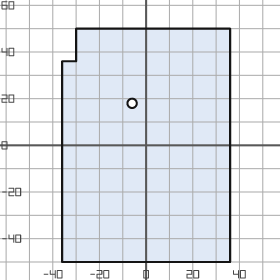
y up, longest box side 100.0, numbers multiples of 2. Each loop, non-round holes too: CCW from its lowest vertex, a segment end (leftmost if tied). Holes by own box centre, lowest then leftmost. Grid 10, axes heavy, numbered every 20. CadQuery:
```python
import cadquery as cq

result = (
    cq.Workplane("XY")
    .moveTo(-36.0, -50.0)
    .lineTo(36.0, -50.0)
    .lineTo(36.0, 50.0)
    .lineTo(-30.0, 50.0)
    .lineTo(-30.0, 36.0)
    .lineTo(-36.0, 36.0)
    .close()
    .moveTo(-6.0, 18.0)
    .circle(2.0)
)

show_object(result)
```